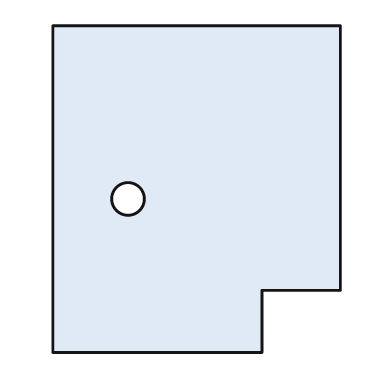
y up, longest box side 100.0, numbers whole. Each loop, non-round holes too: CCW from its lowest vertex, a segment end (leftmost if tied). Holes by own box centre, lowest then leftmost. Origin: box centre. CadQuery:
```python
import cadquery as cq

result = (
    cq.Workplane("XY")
    .moveTo(-44.0, -50.0)
    .lineTo(20.0, -50.0)
    .lineTo(20.0, -31.0)
    .lineTo(44.0, -31.0)
    .lineTo(44.0, 50.0)
    .lineTo(-44.0, 50.0)
    .close()
    .moveTo(-21.0, -3.0)
    .circle(5.0)
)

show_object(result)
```